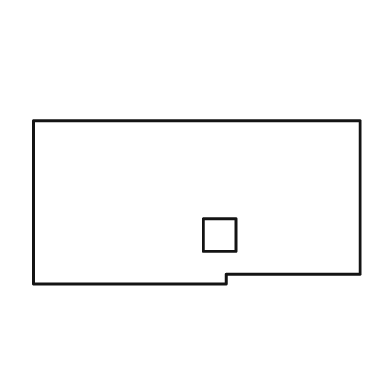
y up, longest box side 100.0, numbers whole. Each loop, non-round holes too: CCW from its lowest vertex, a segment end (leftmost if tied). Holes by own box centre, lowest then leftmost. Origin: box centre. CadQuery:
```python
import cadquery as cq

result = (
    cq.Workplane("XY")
    .moveTo(-50.0, -25.0)
    .lineTo(9.0, -25.0)
    .lineTo(9.0, -22.0)
    .lineTo(50.0, -22.0)
    .lineTo(50.0, 25.0)
    .lineTo(-50.0, 25.0)
    .close()
    .moveTo(2.0, -15.0)
    .lineTo(12.0, -15.0)
    .lineTo(12.0, -5.0)
    .lineTo(2.0, -5.0)
    .close()
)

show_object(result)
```